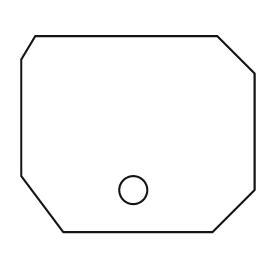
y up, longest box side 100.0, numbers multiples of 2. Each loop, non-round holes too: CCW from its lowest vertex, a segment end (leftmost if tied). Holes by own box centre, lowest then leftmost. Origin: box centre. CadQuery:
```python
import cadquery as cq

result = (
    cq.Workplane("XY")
    .moveTo(-32.0, -42.0)
    .lineTo(32.0, -42.0)
    .lineTo(50.0, -24.0)
    .lineTo(50.0, 26.0)
    .lineTo(34.0, 42.0)
    .lineTo(-44.0, 42.0)
    .lineTo(-50.0, 32.0)
    .lineTo(-50.0, -18.0)
    .close()
    .moveTo(-2.0, -24.0)
    .circle(6.0)
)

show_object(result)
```